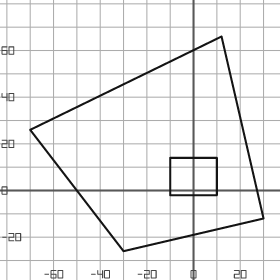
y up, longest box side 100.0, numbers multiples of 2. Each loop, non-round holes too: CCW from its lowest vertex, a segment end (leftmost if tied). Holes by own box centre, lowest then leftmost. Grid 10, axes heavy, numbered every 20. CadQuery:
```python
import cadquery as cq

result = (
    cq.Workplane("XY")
    .moveTo(-30.0, -26.0)
    .lineTo(30.0, -12.0)
    .lineTo(12.0, 66.0)
    .lineTo(-70.0, 26.0)
    .close()
    .moveTo(-10.0, -2.0)
    .lineTo(10.0, -2.0)
    .lineTo(10.0, 14.0)
    .lineTo(-10.0, 14.0)
    .close()
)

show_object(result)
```